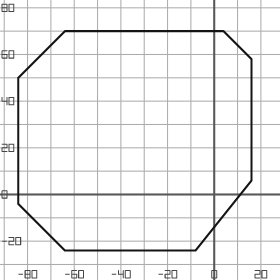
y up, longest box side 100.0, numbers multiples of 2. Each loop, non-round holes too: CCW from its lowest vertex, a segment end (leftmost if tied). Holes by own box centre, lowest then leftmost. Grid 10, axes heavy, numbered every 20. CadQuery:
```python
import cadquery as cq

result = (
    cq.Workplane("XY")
    .moveTo(-64.0, -24.0)
    .lineTo(-8.0, -24.0)
    .lineTo(16.0, 6.0)
    .lineTo(16.0, 58.0)
    .lineTo(4.0, 70.0)
    .lineTo(-64.0, 70.0)
    .lineTo(-84.0, 50.0)
    .lineTo(-84.0, -4.0)
    .close()
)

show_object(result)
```